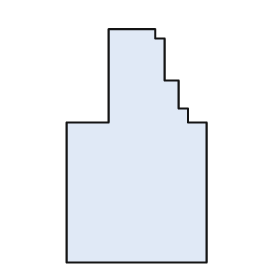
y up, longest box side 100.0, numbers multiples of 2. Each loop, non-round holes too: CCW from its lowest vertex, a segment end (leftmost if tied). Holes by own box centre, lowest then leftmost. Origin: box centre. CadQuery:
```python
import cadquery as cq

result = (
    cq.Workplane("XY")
    .moveTo(-30.0, -50.0)
    .lineTo(30.0, -50.0)
    .lineTo(30.0, 10.0)
    .lineTo(22.0, 10.0)
    .lineTo(22.0, 16.0)
    .lineTo(18.0, 16.0)
    .lineTo(18.0, 28.0)
    .lineTo(12.0, 28.0)
    .lineTo(12.0, 46.0)
    .lineTo(8.0, 46.0)
    .lineTo(8.0, 50.0)
    .lineTo(-12.0, 50.0)
    .lineTo(-12.0, 10.0)
    .lineTo(-30.0, 10.0)
    .close()
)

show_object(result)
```